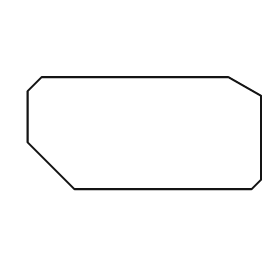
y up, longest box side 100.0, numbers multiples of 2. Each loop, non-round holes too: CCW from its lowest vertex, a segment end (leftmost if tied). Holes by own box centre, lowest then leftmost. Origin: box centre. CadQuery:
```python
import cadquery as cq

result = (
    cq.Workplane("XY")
    .moveTo(-30.0, -24.0)
    .lineTo(46.0, -24.0)
    .lineTo(50.0, -20.0)
    .lineTo(50.0, 16.0)
    .lineTo(36.0, 24.0)
    .lineTo(-44.0, 24.0)
    .lineTo(-50.0, 18.0)
    .lineTo(-50.0, -4.0)
    .close()
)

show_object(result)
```